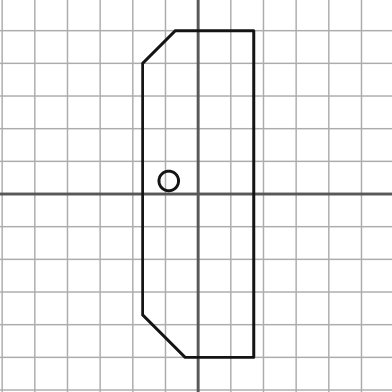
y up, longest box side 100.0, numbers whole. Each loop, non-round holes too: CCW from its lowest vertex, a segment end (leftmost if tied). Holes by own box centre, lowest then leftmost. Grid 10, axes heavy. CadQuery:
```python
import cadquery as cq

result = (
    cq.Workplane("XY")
    .moveTo(-4.0, -50.0)
    .lineTo(17.0, -50.0)
    .lineTo(17.0, 50.0)
    .lineTo(-7.0, 50.0)
    .lineTo(-17.0, 40.0)
    .lineTo(-17.0, -37.0)
    .close()
    .moveTo(-9.0, 4.0)
    .circle(3.0)
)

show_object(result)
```